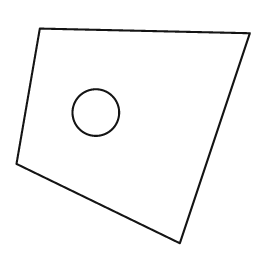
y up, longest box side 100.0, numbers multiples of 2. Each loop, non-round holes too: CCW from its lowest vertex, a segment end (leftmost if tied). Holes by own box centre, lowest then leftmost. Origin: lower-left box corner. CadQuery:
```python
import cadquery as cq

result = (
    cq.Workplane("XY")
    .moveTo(70.0, 0.0)
    .lineTo(100.0, 90.0)
    .lineTo(10.0, 92.0)
    .lineTo(0.0, 34.0)
    .close()
    .moveTo(34.0, 56.0)
    .circle(10.0)
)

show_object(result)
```